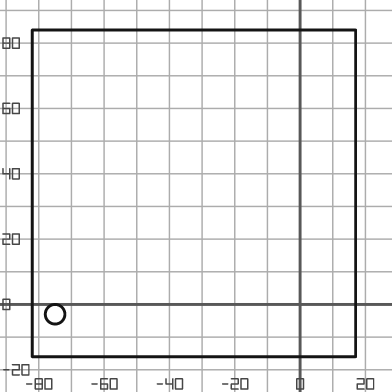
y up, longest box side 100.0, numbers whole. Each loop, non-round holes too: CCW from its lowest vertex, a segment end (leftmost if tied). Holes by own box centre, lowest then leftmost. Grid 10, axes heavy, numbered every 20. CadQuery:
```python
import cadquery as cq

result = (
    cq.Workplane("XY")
    .moveTo(-82.0, -16.0)
    .lineTo(17.0, -16.0)
    .lineTo(17.0, 84.0)
    .lineTo(-82.0, 84.0)
    .close()
    .moveTo(-75.0, -3.0)
    .circle(3.0)
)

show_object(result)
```